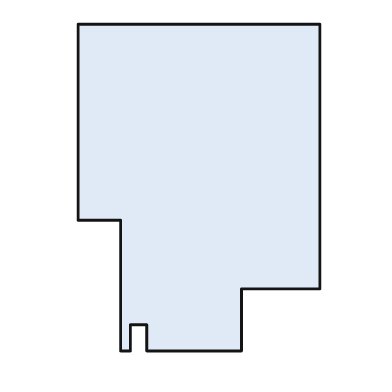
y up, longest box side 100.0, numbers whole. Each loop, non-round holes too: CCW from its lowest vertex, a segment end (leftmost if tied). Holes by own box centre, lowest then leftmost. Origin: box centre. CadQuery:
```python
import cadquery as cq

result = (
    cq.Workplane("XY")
    .moveTo(-24.0, -50.0)
    .lineTo(-21.0, -50.0)
    .lineTo(-21.0, -42.0)
    .lineTo(-16.0, -42.0)
    .lineTo(-16.0, -50.0)
    .lineTo(13.0, -50.0)
    .lineTo(13.0, -31.0)
    .lineTo(37.0, -31.0)
    .lineTo(37.0, 50.0)
    .lineTo(-37.0, 50.0)
    .lineTo(-37.0, -10.0)
    .lineTo(-24.0, -10.0)
    .close()
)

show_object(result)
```